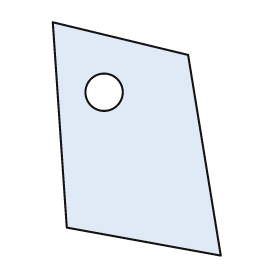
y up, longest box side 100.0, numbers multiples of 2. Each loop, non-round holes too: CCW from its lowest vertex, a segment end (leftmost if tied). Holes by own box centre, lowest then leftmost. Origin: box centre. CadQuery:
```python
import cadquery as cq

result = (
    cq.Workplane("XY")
    .moveTo(36.0, -50.0)
    .lineTo(22.0, 36.0)
    .lineTo(-36.0, 50.0)
    .lineTo(-30.0, -38.0)
    .close()
    .moveTo(-14.0, 20.0)
    .circle(8.0)
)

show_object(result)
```